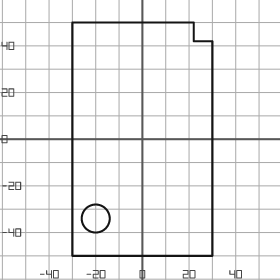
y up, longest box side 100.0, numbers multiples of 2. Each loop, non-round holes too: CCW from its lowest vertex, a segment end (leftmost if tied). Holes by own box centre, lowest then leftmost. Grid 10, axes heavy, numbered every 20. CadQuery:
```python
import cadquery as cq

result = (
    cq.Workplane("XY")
    .moveTo(-30.0, -50.0)
    .lineTo(30.0, -50.0)
    .lineTo(30.0, 42.0)
    .lineTo(22.0, 42.0)
    .lineTo(22.0, 50.0)
    .lineTo(-30.0, 50.0)
    .close()
    .moveTo(-20.0, -34.0)
    .circle(6.0)
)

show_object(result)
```